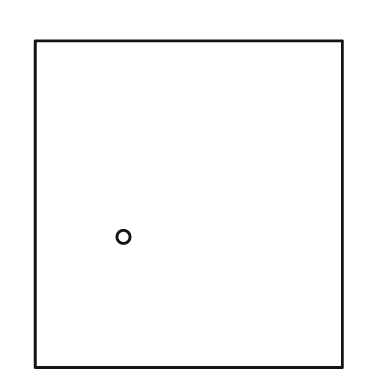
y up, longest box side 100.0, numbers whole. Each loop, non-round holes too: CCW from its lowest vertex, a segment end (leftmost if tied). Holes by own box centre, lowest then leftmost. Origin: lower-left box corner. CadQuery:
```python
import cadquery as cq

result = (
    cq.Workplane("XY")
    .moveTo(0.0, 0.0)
    .lineTo(94.0, 0.0)
    .lineTo(94.0, 100.0)
    .lineTo(0.0, 100.0)
    .close()
    .moveTo(27.0, 40.0)
    .circle(2.0)
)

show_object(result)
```